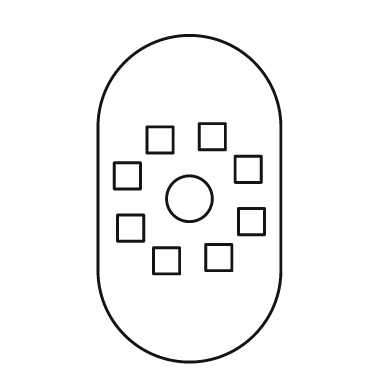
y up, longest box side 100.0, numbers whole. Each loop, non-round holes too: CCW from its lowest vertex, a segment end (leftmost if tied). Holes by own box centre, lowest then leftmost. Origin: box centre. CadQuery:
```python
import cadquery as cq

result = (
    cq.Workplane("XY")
    .moveTo(-28.0, -22.0)
    .threePointArc((0.0, -50.0), (28.0, -22.0))
    .lineTo(28.0, 22.0)
    .threePointArc((0.0, 50.0), (-28.0, 22.0))
    .close()
    .moveTo(-11.0, -23.0)
    .lineTo(-3.0, -23.0)
    .lineTo(-3.0, -15.0)
    .lineTo(-11.0, -15.0)
    .close()
    .moveTo(5.0, -22.0)
    .lineTo(13.0, -22.0)
    .lineTo(13.0, -14.0)
    .lineTo(5.0, -14.0)
    .close()
    .moveTo(-22.0, -13.0)
    .lineTo(-14.0, -13.0)
    .lineTo(-14.0, -5.0)
    .lineTo(-22.0, -5.0)
    .close()
    .moveTo(15.0, -11.0)
    .lineTo(23.0, -11.0)
    .lineTo(23.0, -3.0)
    .lineTo(15.0, -3.0)
    .close()
    .moveTo(0.0, 0.0)
    .circle(7.0)
    .moveTo(-23.0, 3.0)
    .lineTo(-15.0, 3.0)
    .lineTo(-15.0, 11.0)
    .lineTo(-23.0, 11.0)
    .close()
    .moveTo(14.0, 5.0)
    .lineTo(22.0, 5.0)
    .lineTo(22.0, 13.0)
    .lineTo(14.0, 13.0)
    .close()
    .moveTo(-13.0, 14.0)
    .lineTo(-5.0, 14.0)
    .lineTo(-5.0, 22.0)
    .lineTo(-13.0, 22.0)
    .close()
    .moveTo(3.0, 15.0)
    .lineTo(11.0, 15.0)
    .lineTo(11.0, 23.0)
    .lineTo(3.0, 23.0)
    .close()
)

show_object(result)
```